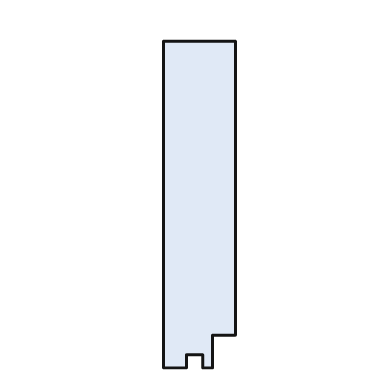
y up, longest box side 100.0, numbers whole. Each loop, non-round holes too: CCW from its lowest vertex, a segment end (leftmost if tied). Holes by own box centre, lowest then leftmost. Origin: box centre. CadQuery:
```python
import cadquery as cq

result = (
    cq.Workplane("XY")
    .moveTo(-11.0, -50.0)
    .lineTo(-4.0, -50.0)
    .lineTo(-4.0, -46.0)
    .lineTo(1.0, -46.0)
    .lineTo(1.0, -50.0)
    .lineTo(4.0, -50.0)
    .lineTo(4.0, -40.0)
    .lineTo(11.0, -40.0)
    .lineTo(11.0, 50.0)
    .lineTo(-11.0, 50.0)
    .close()
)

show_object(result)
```